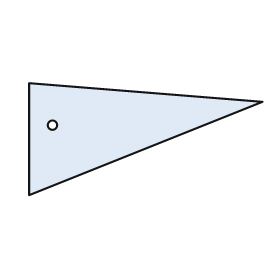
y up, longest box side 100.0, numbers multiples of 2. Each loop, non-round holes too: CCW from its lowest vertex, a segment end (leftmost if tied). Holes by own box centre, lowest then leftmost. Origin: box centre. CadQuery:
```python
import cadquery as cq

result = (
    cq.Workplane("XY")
    .moveTo(-50.0, -24.0)
    .lineTo(50.0, 16.0)
    .lineTo(-50.0, 24.0)
    .close()
    .moveTo(-40.0, 6.0)
    .circle(2.0)
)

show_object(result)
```